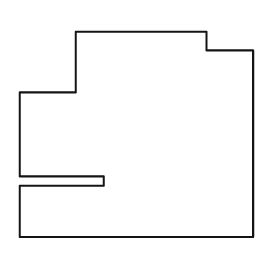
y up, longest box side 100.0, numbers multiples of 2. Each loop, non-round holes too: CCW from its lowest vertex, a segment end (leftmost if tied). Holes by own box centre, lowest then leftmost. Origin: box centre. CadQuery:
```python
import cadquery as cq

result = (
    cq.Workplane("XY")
    .moveTo(-50.0, -44.0)
    .lineTo(50.0, -44.0)
    .lineTo(50.0, 36.0)
    .lineTo(30.0, 36.0)
    .lineTo(30.0, 44.0)
    .lineTo(-26.0, 44.0)
    .lineTo(-26.0, 18.0)
    .lineTo(-50.0, 18.0)
    .lineTo(-50.0, -18.0)
    .lineTo(-14.0, -18.0)
    .lineTo(-14.0, -22.0)
    .lineTo(-50.0, -22.0)
    .close()
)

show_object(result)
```